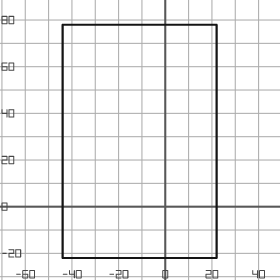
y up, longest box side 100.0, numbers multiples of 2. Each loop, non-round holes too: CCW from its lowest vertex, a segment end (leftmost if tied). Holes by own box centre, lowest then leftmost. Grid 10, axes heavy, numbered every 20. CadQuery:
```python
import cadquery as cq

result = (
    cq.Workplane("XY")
    .moveTo(-44.0, -22.0)
    .lineTo(22.0, -22.0)
    .lineTo(22.0, 78.0)
    .lineTo(-44.0, 78.0)
    .close()
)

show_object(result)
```